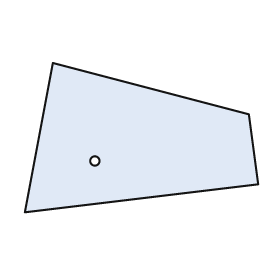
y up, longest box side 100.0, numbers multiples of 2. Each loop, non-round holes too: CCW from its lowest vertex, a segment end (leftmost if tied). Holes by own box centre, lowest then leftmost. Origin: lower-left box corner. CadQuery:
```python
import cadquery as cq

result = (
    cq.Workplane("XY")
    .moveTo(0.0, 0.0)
    .lineTo(100.0, 12.0)
    .lineTo(96.0, 42.0)
    .lineTo(12.0, 64.0)
    .close()
    .moveTo(30.0, 22.0)
    .circle(2.0)
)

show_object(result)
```